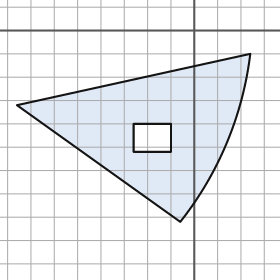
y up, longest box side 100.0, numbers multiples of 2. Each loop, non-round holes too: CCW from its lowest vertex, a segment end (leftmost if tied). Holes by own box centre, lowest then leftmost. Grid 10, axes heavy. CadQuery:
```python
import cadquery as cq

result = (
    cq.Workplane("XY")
    .moveTo(-6.0, -82.0)
    .threePointArc((14.0, -48.0), (24.0, -10.0))
    .lineTo(-76.0, -32.0)
    .close()
    .moveTo(-26.0, -52.0)
    .lineTo(-10.0, -52.0)
    .lineTo(-10.0, -40.0)
    .lineTo(-26.0, -40.0)
    .close()
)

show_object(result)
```